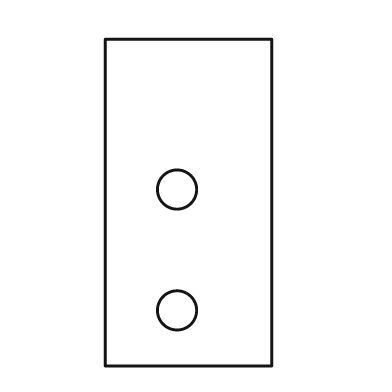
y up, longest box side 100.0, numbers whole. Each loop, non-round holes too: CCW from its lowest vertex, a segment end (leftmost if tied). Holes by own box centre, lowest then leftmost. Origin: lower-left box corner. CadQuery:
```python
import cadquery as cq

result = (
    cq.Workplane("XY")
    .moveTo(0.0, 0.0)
    .lineTo(51.0, 0.0)
    .lineTo(51.0, 100.0)
    .lineTo(0.0, 100.0)
    .close()
    .moveTo(22.0, 17.0)
    .circle(6.0)
    .moveTo(22.0, 54.0)
    .circle(6.0)
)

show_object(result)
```